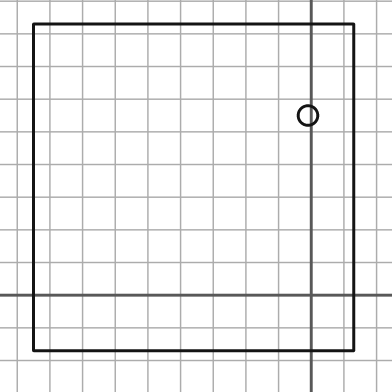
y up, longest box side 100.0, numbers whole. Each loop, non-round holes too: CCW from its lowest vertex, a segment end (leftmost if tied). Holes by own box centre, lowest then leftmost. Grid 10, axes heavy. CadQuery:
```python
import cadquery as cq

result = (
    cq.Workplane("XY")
    .moveTo(-85.0, -17.0)
    .lineTo(13.0, -17.0)
    .lineTo(13.0, 83.0)
    .lineTo(-85.0, 83.0)
    .close()
    .moveTo(-1.0, 55.0)
    .circle(3.0)
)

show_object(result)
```